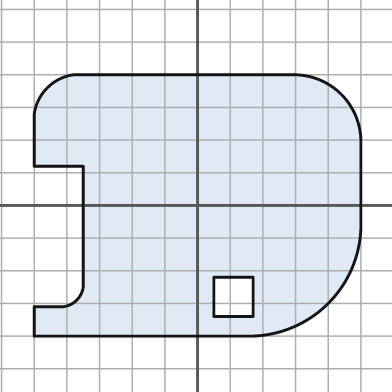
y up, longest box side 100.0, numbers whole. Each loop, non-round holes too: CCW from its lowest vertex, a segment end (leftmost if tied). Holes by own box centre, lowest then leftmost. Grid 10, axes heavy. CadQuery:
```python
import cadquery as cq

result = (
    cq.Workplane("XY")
    .moveTo(-50.0, -40.0)
    .lineTo(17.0, -40.0)
    .threePointArc((40.0, -30.0), (50.0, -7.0))
    .lineTo(50.0, 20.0)
    .threePointArc((44.0, 34.0), (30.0, 40.0))
    .lineTo(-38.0, 40.0)
    .threePointArc((-46.0, 36.0), (-50.0, 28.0))
    .lineTo(-50.0, 12.0)
    .lineTo(-35.0, 12.0)
    .lineTo(-35.0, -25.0)
    .threePointArc((-37.0, -29.0), (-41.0, -31.0))
    .lineTo(-50.0, -31.0)
    .close()
    .moveTo(5.0, -34.0)
    .lineTo(17.0, -34.0)
    .lineTo(17.0, -22.0)
    .lineTo(5.0, -22.0)
    .close()
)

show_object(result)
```